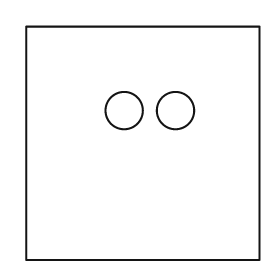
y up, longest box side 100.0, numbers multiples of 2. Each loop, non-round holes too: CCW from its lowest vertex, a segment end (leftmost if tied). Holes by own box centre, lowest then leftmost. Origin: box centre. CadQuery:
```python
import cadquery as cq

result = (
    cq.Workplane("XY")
    .moveTo(-50.0, -50.0)
    .lineTo(50.0, -50.0)
    .lineTo(50.0, 50.0)
    .lineTo(-50.0, 50.0)
    .close()
    .moveTo(-8.0, 14.0)
    .circle(8.0)
    .moveTo(14.0, 14.0)
    .circle(8.0)
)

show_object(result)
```